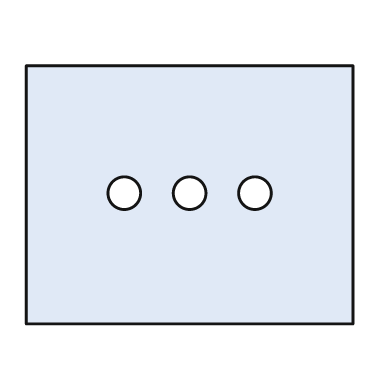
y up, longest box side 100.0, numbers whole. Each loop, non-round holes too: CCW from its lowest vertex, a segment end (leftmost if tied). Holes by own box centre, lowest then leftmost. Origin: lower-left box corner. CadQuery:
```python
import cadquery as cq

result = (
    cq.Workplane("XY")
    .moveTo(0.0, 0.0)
    .lineTo(100.0, 0.0)
    .lineTo(100.0, 79.0)
    .lineTo(0.0, 79.0)
    .close()
    .moveTo(30.0, 40.0)
    .circle(5.0)
    .moveTo(50.0, 40.0)
    .circle(5.0)
    .moveTo(70.0, 40.0)
    .circle(5.0)
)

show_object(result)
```